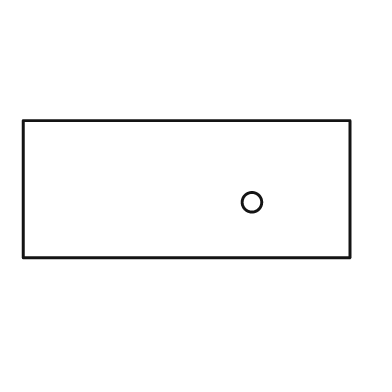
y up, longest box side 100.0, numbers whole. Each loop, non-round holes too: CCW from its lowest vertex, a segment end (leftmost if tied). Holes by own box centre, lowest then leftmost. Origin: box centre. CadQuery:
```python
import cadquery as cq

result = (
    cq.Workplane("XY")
    .moveTo(-50.0, -21.0)
    .lineTo(50.0, -21.0)
    .lineTo(50.0, 21.0)
    .lineTo(-50.0, 21.0)
    .close()
    .moveTo(20.0, -4.0)
    .circle(3.0)
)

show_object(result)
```